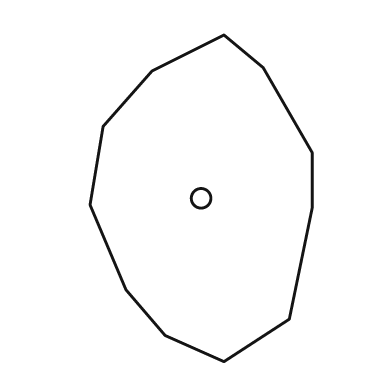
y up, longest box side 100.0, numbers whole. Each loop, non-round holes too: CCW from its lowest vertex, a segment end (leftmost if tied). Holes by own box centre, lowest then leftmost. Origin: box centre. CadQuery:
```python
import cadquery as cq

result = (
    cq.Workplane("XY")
    .moveTo(7.0, -50.0)
    .lineTo(27.0, -37.0)
    .lineTo(34.0, -3.0)
    .lineTo(34.0, 14.0)
    .lineTo(19.0, 40.0)
    .lineTo(7.0, 50.0)
    .lineTo(-15.0, 39.0)
    .lineTo(-30.0, 22.0)
    .lineTo(-34.0, -2.0)
    .lineTo(-23.0, -28.0)
    .lineTo(-11.0, -42.0)
    .close()
    .moveTo(0.0, 0.0)
    .circle(3.0)
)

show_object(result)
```